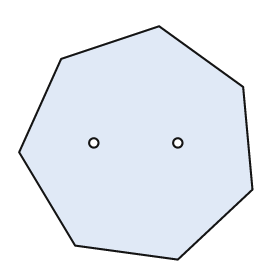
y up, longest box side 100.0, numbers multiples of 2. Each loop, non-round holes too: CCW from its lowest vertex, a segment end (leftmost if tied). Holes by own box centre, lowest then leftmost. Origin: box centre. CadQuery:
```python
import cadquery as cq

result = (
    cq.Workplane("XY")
    .moveTo(18.0, -50.0)
    .lineTo(50.0, -20.0)
    .lineTo(46.0, 24.0)
    .lineTo(10.0, 50.0)
    .lineTo(-32.0, 36.0)
    .lineTo(-50.0, -4.0)
    .lineTo(-26.0, -44.0)
    .close()
    .moveTo(-18.0, 0.0)
    .circle(2.0)
    .moveTo(18.0, 0.0)
    .circle(2.0)
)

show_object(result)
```